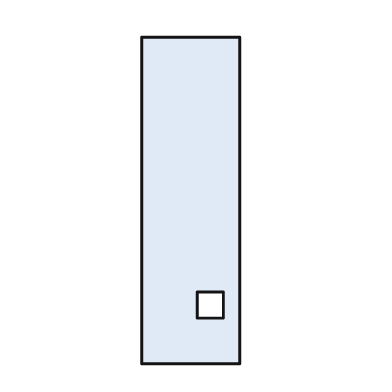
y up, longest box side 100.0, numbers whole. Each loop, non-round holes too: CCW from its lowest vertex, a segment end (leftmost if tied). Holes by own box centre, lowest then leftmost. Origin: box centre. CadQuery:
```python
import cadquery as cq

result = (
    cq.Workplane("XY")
    .moveTo(-15.0, -50.0)
    .lineTo(15.0, -50.0)
    .lineTo(15.0, 50.0)
    .lineTo(-15.0, 50.0)
    .close()
    .moveTo(2.0, -36.0)
    .lineTo(10.0, -36.0)
    .lineTo(10.0, -28.0)
    .lineTo(2.0, -28.0)
    .close()
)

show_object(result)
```